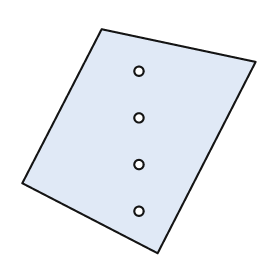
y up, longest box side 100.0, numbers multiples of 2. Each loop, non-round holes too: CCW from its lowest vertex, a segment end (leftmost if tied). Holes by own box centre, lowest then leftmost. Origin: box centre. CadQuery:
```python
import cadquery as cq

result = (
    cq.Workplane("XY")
    .moveTo(8.0, -48.0)
    .lineTo(50.0, 34.0)
    .lineTo(-16.0, 48.0)
    .lineTo(-50.0, -18.0)
    .close()
    .moveTo(0.0, -30.0)
    .circle(2.0)
    .moveTo(0.0, -10.0)
    .circle(2.0)
    .moveTo(0.0, 10.0)
    .circle(2.0)
    .moveTo(0.0, 30.0)
    .circle(2.0)
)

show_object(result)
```